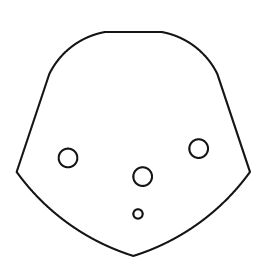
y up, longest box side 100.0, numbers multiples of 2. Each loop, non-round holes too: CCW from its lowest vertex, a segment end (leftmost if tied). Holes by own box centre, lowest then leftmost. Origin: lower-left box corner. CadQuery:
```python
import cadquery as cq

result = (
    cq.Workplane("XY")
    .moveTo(50.0, 0.0)
    .threePointArc((78.0, 14.0), (100.0, 36.0))
    .lineTo(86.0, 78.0)
    .threePointArc((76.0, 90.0), (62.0, 96.0))
    .lineTo(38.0, 96.0)
    .threePointArc((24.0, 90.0), (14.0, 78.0))
    .lineTo(0.0, 36.0)
    .threePointArc((22.0, 14.0), (50.0, 0.0))
    .close()
    .moveTo(52.0, 18.0)
    .circle(2.0)
    .moveTo(54.0, 34.0)
    .circle(4.0)
    .moveTo(22.0, 42.0)
    .circle(4.0)
    .moveTo(78.0, 46.0)
    .circle(4.0)
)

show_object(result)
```